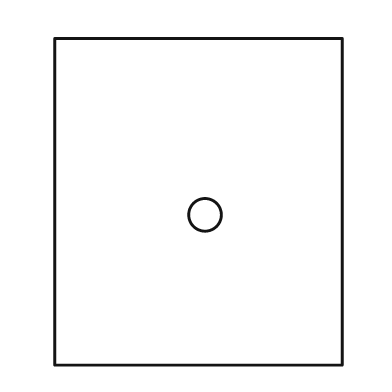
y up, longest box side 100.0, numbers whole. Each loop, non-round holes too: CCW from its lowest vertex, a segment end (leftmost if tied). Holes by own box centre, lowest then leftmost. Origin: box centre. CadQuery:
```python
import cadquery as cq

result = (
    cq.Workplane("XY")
    .moveTo(-44.0, -50.0)
    .lineTo(44.0, -50.0)
    .lineTo(44.0, 50.0)
    .lineTo(-44.0, 50.0)
    .close()
    .moveTo(2.0, -4.0)
    .circle(5.0)
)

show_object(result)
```